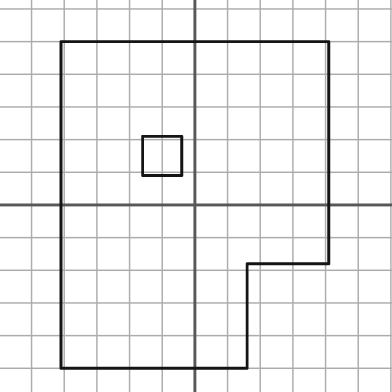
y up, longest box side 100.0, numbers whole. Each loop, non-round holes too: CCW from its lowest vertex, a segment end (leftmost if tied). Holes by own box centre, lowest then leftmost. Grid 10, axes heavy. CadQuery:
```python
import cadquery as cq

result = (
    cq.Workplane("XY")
    .moveTo(-41.0, -50.0)
    .lineTo(16.0, -50.0)
    .lineTo(16.0, -18.0)
    .lineTo(41.0, -18.0)
    .lineTo(41.0, 50.0)
    .lineTo(-41.0, 50.0)
    .close()
    .moveTo(-16.0, 9.0)
    .lineTo(-4.0, 9.0)
    .lineTo(-4.0, 21.0)
    .lineTo(-16.0, 21.0)
    .close()
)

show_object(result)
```